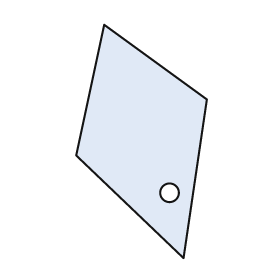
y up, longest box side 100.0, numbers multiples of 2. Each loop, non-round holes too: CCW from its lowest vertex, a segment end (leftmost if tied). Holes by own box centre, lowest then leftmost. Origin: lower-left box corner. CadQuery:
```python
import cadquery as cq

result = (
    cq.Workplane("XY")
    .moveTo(46.0, 0.0)
    .lineTo(56.0, 68.0)
    .lineTo(12.0, 100.0)
    .lineTo(0.0, 44.0)
    .close()
    .moveTo(40.0, 28.0)
    .circle(4.0)
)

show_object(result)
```